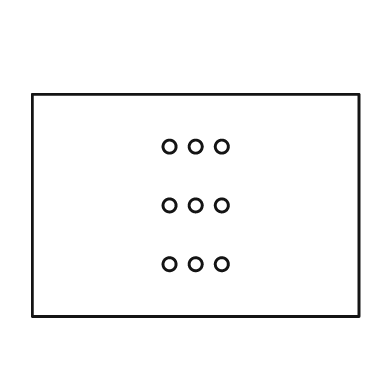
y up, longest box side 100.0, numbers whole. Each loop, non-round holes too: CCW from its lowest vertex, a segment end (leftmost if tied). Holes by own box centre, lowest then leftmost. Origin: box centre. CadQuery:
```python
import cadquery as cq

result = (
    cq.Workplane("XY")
    .moveTo(-50.0, -34.0)
    .lineTo(50.0, -34.0)
    .lineTo(50.0, 34.0)
    .lineTo(-50.0, 34.0)
    .close()
    .moveTo(-8.0, -18.0)
    .circle(2.0)
    .moveTo(0.0, -18.0)
    .circle(2.0)
    .moveTo(8.0, -18.0)
    .circle(2.0)
    .moveTo(-8.0, 0.0)
    .circle(2.0)
    .moveTo(0.0, 0.0)
    .circle(2.0)
    .moveTo(8.0, 0.0)
    .circle(2.0)
    .moveTo(-8.0, 18.0)
    .circle(2.0)
    .moveTo(0.0, 18.0)
    .circle(2.0)
    .moveTo(8.0, 18.0)
    .circle(2.0)
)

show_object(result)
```